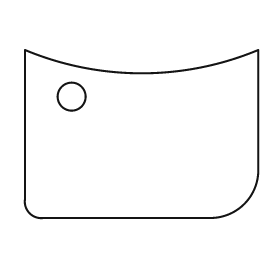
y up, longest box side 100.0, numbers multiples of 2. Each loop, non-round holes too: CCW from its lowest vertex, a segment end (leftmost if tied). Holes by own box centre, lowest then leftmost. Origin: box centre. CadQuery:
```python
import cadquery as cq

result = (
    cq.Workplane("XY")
    .moveTo(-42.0, -36.0)
    .lineTo(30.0, -36.0)
    .threePointArc((44.0, -30.0), (50.0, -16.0))
    .lineTo(50.0, 36.0)
    .threePointArc((0.0, 26.0), (-50.0, 36.0))
    .lineTo(-50.0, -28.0)
    .threePointArc((-48.0, -34.0), (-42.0, -36.0))
    .close()
    .moveTo(-30.0, 16.0)
    .circle(6.0)
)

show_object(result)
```